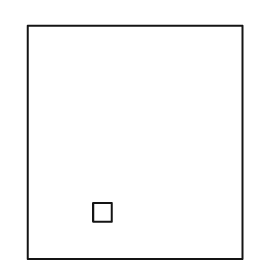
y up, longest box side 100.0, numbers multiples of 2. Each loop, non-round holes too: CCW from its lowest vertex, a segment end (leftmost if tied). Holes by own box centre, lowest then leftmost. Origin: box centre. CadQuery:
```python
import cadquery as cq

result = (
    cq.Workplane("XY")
    .moveTo(-46.0, -50.0)
    .lineTo(46.0, -50.0)
    .lineTo(46.0, 50.0)
    .lineTo(-46.0, 50.0)
    .close()
    .moveTo(-18.0, -34.0)
    .lineTo(-10.0, -34.0)
    .lineTo(-10.0, -26.0)
    .lineTo(-18.0, -26.0)
    .close()
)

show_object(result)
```